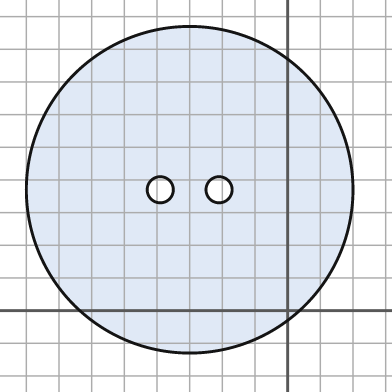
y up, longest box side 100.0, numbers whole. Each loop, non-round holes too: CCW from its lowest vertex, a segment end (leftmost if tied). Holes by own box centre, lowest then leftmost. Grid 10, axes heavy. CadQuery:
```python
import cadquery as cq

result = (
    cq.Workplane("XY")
    .moveTo(-30.0, 37.0)
    .circle(50.0)
    .moveTo(-39.0, 37.0)
    .circle(4.0)
    .moveTo(-21.0, 37.0)
    .circle(4.0)
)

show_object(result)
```